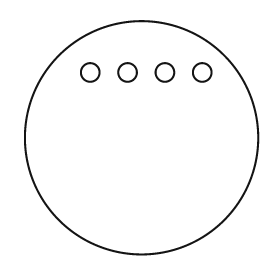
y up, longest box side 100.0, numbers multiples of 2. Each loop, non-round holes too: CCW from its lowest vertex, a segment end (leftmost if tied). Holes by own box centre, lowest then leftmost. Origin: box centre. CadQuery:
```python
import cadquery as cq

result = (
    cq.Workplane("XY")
    .moveTo(0.0, 0.0)
    .circle(50.0)
    .moveTo(-22.0, 28.0)
    .circle(4.0)
    .moveTo(-6.0, 28.0)
    .circle(4.0)
    .moveTo(10.0, 28.0)
    .circle(4.0)
    .moveTo(26.0, 28.0)
    .circle(4.0)
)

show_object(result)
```